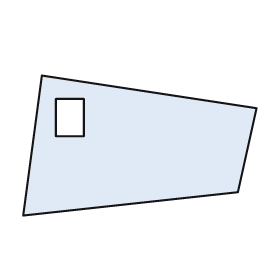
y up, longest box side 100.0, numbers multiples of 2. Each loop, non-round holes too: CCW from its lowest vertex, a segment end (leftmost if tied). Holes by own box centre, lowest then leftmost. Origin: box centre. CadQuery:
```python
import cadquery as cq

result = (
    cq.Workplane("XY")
    .moveTo(-50.0, -30.0)
    .lineTo(42.0, -20.0)
    .lineTo(50.0, 16.0)
    .lineTo(-42.0, 30.0)
    .close()
    .moveTo(-36.0, 4.0)
    .lineTo(-24.0, 4.0)
    .lineTo(-24.0, 20.0)
    .lineTo(-36.0, 20.0)
    .close()
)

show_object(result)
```